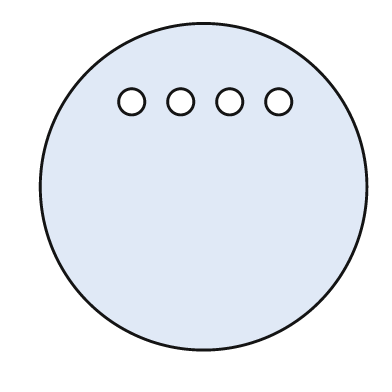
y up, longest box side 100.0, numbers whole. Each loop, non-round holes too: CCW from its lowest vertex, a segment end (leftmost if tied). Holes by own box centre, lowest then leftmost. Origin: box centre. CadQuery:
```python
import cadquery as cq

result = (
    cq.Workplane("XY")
    .moveTo(0.0, 0.0)
    .circle(50.0)
    .moveTo(-22.0, 26.0)
    .circle(4.0)
    .moveTo(-7.0, 26.0)
    .circle(4.0)
    .moveTo(8.0, 26.0)
    .circle(4.0)
    .moveTo(23.0, 26.0)
    .circle(4.0)
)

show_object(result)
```